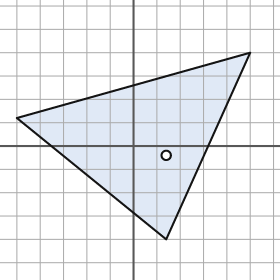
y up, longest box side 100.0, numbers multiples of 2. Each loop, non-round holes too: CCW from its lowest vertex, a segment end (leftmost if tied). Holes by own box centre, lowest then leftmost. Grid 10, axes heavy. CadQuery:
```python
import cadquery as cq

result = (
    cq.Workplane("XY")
    .moveTo(14.0, -40.0)
    .lineTo(50.0, 40.0)
    .lineTo(-50.0, 12.0)
    .close()
    .moveTo(14.0, -4.0)
    .circle(2.0)
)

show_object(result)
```